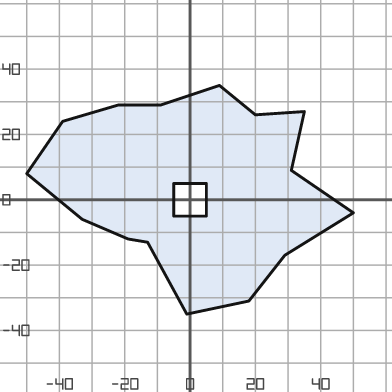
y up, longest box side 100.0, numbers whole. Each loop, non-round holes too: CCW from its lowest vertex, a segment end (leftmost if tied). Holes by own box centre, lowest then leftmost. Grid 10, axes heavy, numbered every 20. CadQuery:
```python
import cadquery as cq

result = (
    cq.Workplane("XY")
    .moveTo(-1.0, -35.0)
    .lineTo(18.0, -31.0)
    .lineTo(29.0, -17.0)
    .lineTo(50.0, -4.0)
    .lineTo(31.0, 9.0)
    .lineTo(35.0, 27.0)
    .lineTo(20.0, 26.0)
    .lineTo(9.0, 35.0)
    .lineTo(-9.0, 29.0)
    .lineTo(-22.0, 29.0)
    .lineTo(-39.0, 24.0)
    .lineTo(-50.0, 8.0)
    .lineTo(-33.0, -6.0)
    .lineTo(-19.0, -12.0)
    .lineTo(-13.0, -13.0)
    .close()
    .moveTo(-5.0, -5.0)
    .lineTo(5.0, -5.0)
    .lineTo(5.0, 5.0)
    .lineTo(-5.0, 5.0)
    .close()
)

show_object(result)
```